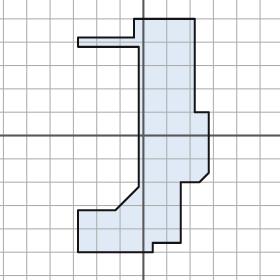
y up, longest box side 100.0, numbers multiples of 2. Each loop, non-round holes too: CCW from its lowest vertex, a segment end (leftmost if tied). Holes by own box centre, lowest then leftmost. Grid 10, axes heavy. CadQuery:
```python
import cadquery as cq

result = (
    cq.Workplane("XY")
    .moveTo(-28.0, -50.0)
    .lineTo(4.0, -50.0)
    .lineTo(4.0, -46.0)
    .lineTo(16.0, -46.0)
    .lineTo(16.0, -20.0)
    .lineTo(24.0, -20.0)
    .lineTo(28.0, -16.0)
    .lineTo(28.0, 10.0)
    .lineTo(22.0, 10.0)
    .lineTo(22.0, 50.0)
    .lineTo(-4.0, 50.0)
    .lineTo(-4.0, 42.0)
    .lineTo(-28.0, 42.0)
    .lineTo(-28.0, 38.0)
    .lineTo(-2.0, 38.0)
    .lineTo(-2.0, -22.0)
    .lineTo(-12.0, -32.0)
    .lineTo(-28.0, -32.0)
    .close()
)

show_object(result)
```